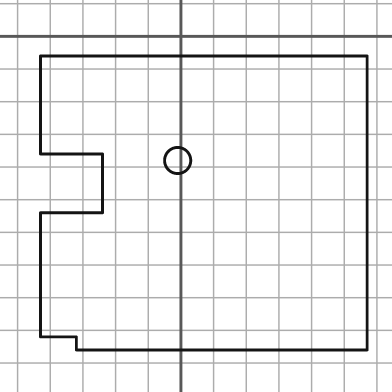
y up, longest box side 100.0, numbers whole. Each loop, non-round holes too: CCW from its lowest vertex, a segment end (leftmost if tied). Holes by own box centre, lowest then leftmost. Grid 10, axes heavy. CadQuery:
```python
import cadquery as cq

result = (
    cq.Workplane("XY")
    .moveTo(-32.0, -96.0)
    .lineTo(57.0, -96.0)
    .lineTo(57.0, -6.0)
    .lineTo(-43.0, -6.0)
    .lineTo(-43.0, -36.0)
    .lineTo(-24.0, -36.0)
    .lineTo(-24.0, -54.0)
    .lineTo(-43.0, -54.0)
    .lineTo(-43.0, -92.0)
    .lineTo(-32.0, -92.0)
    .close()
    .moveTo(-1.0, -38.0)
    .circle(4.0)
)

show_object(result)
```